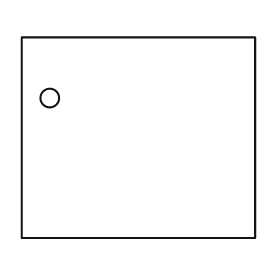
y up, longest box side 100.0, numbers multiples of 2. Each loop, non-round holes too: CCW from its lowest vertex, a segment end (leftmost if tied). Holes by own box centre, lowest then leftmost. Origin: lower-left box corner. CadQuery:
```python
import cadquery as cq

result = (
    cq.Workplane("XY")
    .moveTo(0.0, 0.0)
    .lineTo(100.0, 0.0)
    .lineTo(100.0, 86.0)
    .lineTo(0.0, 86.0)
    .close()
    .moveTo(12.0, 60.0)
    .circle(4.0)
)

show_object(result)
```